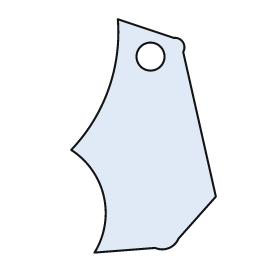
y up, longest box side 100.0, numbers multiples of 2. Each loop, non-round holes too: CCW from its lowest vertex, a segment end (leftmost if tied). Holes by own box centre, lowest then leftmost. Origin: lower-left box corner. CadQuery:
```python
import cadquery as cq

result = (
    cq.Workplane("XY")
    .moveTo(10.0, 0.0)
    .lineTo(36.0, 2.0)
    .threePointArc((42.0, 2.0), (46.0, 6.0))
    .lineTo(62.0, 24.0)
    .lineTo(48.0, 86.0)
    .threePointArc((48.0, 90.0), (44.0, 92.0))
    .lineTo(20.0, 100.0)
    .threePointArc((16.0, 70.0), (0.0, 44.0))
    .threePointArc((14.0, 24.0), (10.0, 0.0))
    .close()
    .moveTo(34.0, 84.0)
    .circle(6.0)
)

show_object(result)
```